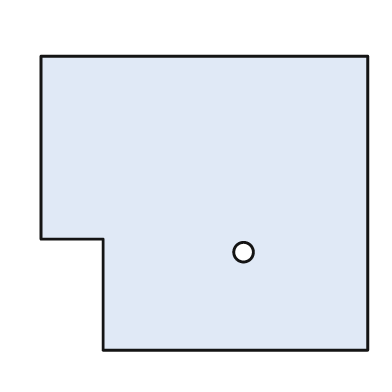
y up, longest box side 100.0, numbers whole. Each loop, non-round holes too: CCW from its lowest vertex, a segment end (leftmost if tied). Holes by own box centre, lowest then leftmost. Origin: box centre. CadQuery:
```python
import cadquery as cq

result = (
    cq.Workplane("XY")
    .moveTo(-31.0, -45.0)
    .lineTo(50.0, -45.0)
    .lineTo(50.0, 45.0)
    .lineTo(-50.0, 45.0)
    .lineTo(-50.0, -11.0)
    .lineTo(-31.0, -11.0)
    .close()
    .moveTo(12.0, -15.0)
    .circle(3.0)
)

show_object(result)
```